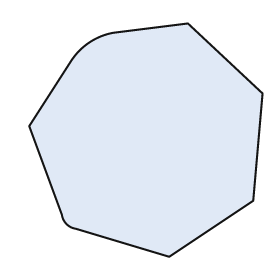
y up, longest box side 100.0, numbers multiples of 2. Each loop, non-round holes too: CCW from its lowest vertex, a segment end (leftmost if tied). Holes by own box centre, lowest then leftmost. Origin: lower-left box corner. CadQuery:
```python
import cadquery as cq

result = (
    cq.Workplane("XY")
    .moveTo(60.0, 0.0)
    .lineTo(96.0, 24.0)
    .lineTo(100.0, 70.0)
    .lineTo(68.0, 100.0)
    .lineTo(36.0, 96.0)
    .threePointArc((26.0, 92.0), (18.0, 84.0))
    .lineTo(0.0, 56.0)
    .lineTo(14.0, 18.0)
    .threePointArc((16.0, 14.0), (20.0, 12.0))
    .close()
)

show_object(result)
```